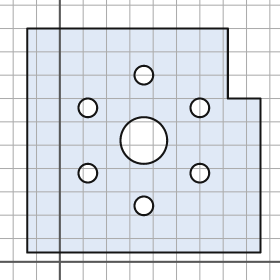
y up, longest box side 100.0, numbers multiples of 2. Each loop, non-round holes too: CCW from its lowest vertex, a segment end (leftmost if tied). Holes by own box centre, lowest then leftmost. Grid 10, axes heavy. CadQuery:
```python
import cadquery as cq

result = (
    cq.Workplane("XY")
    .moveTo(-14.0, 4.0)
    .lineTo(86.0, 4.0)
    .lineTo(86.0, 70.0)
    .lineTo(72.0, 70.0)
    .lineTo(72.0, 100.0)
    .lineTo(-14.0, 100.0)
    .close()
    .moveTo(36.0, 24.0)
    .circle(4.0)
    .moveTo(12.0, 38.0)
    .circle(4.0)
    .moveTo(60.0, 38.0)
    .circle(4.0)
    .moveTo(36.0, 52.0)
    .circle(10.0)
    .moveTo(12.0, 66.0)
    .circle(4.0)
    .moveTo(60.0, 66.0)
    .circle(4.0)
    .moveTo(36.0, 80.0)
    .circle(4.0)
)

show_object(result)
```